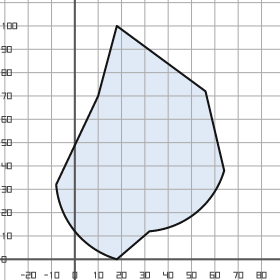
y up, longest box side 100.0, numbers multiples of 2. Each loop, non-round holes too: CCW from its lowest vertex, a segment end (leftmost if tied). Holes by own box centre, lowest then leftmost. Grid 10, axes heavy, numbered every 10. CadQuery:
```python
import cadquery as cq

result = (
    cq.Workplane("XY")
    .moveTo(18.0, 0.0)
    .lineTo(32.0, 12.0)
    .threePointArc((52.0, 20.0), (64.0, 38.0))
    .lineTo(56.0, 72.0)
    .lineTo(18.0, 100.0)
    .lineTo(10.0, 70.0)
    .lineTo(-8.0, 32.0)
    .threePointArc((0.0, 12.0), (18.0, 0.0))
    .close()
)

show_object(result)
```